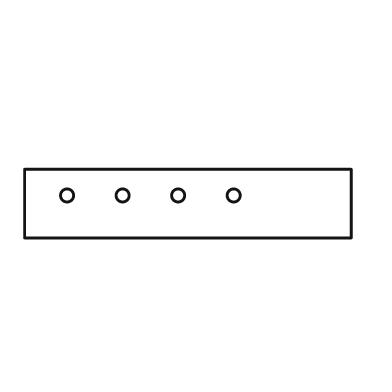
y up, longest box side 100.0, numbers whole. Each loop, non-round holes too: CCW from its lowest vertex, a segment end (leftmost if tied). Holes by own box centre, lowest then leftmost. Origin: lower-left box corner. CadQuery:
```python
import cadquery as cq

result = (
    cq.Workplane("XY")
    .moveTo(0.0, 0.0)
    .lineTo(100.0, 0.0)
    .lineTo(100.0, 21.0)
    .lineTo(0.0, 21.0)
    .close()
    .moveTo(13.0, 13.0)
    .circle(2.0)
    .moveTo(30.0, 13.0)
    .circle(2.0)
    .moveTo(47.0, 13.0)
    .circle(2.0)
    .moveTo(64.0, 13.0)
    .circle(2.0)
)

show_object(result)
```